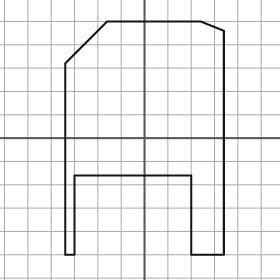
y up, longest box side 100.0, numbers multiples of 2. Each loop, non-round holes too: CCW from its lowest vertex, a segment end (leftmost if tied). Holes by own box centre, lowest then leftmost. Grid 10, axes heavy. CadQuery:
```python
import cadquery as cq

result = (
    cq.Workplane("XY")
    .moveTo(-34.0, -50.0)
    .lineTo(-30.0, -50.0)
    .lineTo(-30.0, -16.0)
    .lineTo(20.0, -16.0)
    .lineTo(20.0, -50.0)
    .lineTo(34.0, -50.0)
    .lineTo(34.0, 46.0)
    .lineTo(24.0, 50.0)
    .lineTo(-16.0, 50.0)
    .lineTo(-34.0, 32.0)
    .close()
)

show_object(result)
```